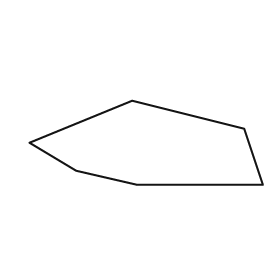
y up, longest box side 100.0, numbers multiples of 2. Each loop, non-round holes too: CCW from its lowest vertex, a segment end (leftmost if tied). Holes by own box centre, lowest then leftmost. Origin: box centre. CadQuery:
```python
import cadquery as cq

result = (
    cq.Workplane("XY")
    .moveTo(-4.0, -18.0)
    .lineTo(50.0, -18.0)
    .lineTo(42.0, 6.0)
    .lineTo(-6.0, 18.0)
    .lineTo(-50.0, 0.0)
    .lineTo(-30.0, -12.0)
    .close()
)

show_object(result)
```